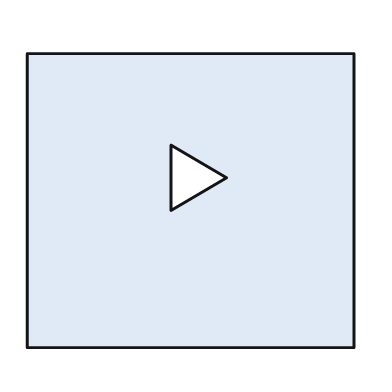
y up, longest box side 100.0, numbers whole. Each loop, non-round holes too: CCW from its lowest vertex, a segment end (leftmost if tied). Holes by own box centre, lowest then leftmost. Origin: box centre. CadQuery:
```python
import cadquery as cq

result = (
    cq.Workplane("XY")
    .moveTo(-50.0, -45.0)
    .lineTo(50.0, -45.0)
    .lineTo(50.0, 45.0)
    .lineTo(-50.0, 45.0)
    .close()
    .moveTo(-6.0, -3.0)
    .lineTo(11.0, 7.0)
    .lineTo(-6.0, 17.0)
    .close()
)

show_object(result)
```